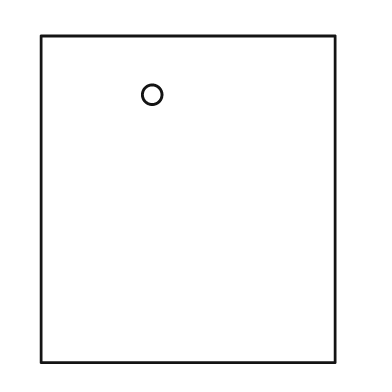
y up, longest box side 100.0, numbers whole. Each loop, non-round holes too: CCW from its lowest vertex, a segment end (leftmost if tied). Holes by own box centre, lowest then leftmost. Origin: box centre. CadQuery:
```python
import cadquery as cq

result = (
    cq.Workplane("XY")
    .moveTo(-45.0, -50.0)
    .lineTo(45.0, -50.0)
    .lineTo(45.0, 50.0)
    .lineTo(-45.0, 50.0)
    .close()
    .moveTo(-11.0, 32.0)
    .circle(3.0)
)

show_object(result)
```